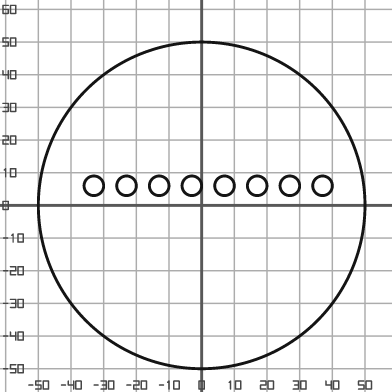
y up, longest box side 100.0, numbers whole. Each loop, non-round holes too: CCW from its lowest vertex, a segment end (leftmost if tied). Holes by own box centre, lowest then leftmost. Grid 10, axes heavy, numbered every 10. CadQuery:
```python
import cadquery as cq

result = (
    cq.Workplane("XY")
    .moveTo(0.0, 0.0)
    .circle(50.0)
    .moveTo(-33.0, 6.0)
    .circle(3.0)
    .moveTo(-23.0, 6.0)
    .circle(3.0)
    .moveTo(-13.0, 6.0)
    .circle(3.0)
    .moveTo(-3.0, 6.0)
    .circle(3.0)
    .moveTo(7.0, 6.0)
    .circle(3.0)
    .moveTo(17.0, 6.0)
    .circle(3.0)
    .moveTo(27.0, 6.0)
    .circle(3.0)
    .moveTo(37.0, 6.0)
    .circle(3.0)
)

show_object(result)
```